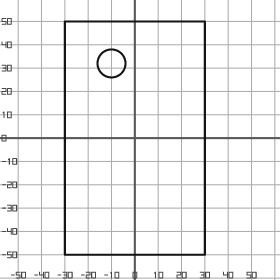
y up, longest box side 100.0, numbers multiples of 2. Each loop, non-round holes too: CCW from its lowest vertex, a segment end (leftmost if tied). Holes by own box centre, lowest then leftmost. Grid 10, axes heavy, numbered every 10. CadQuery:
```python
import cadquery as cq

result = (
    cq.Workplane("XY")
    .moveTo(-30.0, -50.0)
    .lineTo(30.0, -50.0)
    .lineTo(30.0, 50.0)
    .lineTo(-30.0, 50.0)
    .close()
    .moveTo(-10.0, 32.0)
    .circle(6.0)
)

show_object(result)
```